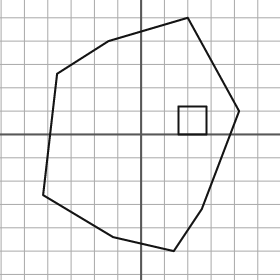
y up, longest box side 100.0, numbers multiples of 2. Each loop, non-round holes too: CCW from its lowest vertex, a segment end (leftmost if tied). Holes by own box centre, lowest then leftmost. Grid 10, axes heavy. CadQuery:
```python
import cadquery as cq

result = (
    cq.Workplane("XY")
    .moveTo(14.0, -50.0)
    .lineTo(26.0, -32.0)
    .lineTo(42.0, 10.0)
    .lineTo(20.0, 50.0)
    .lineTo(-14.0, 40.0)
    .lineTo(-36.0, 26.0)
    .lineTo(-42.0, -26.0)
    .lineTo(-12.0, -44.0)
    .close()
    .moveTo(16.0, 0.0)
    .lineTo(28.0, 0.0)
    .lineTo(28.0, 12.0)
    .lineTo(16.0, 12.0)
    .close()
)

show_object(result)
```